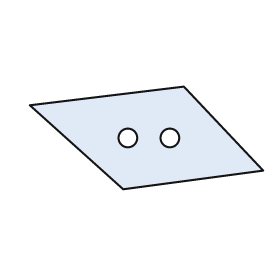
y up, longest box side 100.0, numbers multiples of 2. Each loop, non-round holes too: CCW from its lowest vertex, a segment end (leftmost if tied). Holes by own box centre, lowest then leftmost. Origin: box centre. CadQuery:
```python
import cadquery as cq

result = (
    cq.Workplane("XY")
    .moveTo(-10.0, -22.0)
    .lineTo(50.0, -14.0)
    .lineTo(16.0, 22.0)
    .lineTo(-50.0, 14.0)
    .close()
    .moveTo(-8.0, 0.0)
    .circle(4.0)
    .moveTo(10.0, 0.0)
    .circle(4.0)
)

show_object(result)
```